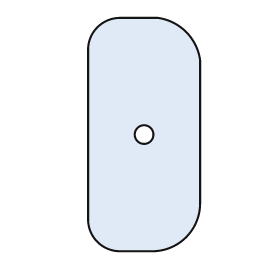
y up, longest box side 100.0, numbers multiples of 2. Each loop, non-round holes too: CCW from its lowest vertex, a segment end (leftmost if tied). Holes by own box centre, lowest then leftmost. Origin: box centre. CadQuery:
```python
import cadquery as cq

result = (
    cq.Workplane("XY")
    .moveTo(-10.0, -50.0)
    .lineTo(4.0, -50.0)
    .threePointArc((18.0, -44.0), (24.0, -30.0))
    .lineTo(24.0, 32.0)
    .threePointArc((18.0, 44.0), (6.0, 50.0))
    .lineTo(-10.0, 50.0)
    .threePointArc((-20.0, 46.0), (-24.0, 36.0))
    .lineTo(-24.0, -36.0)
    .threePointArc((-20.0, -46.0), (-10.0, -50.0))
    .close()
    .moveTo(0.0, 0.0)
    .circle(4.0)
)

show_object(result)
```